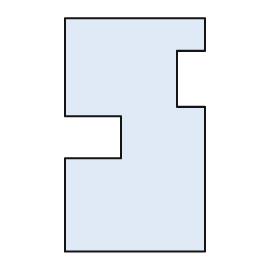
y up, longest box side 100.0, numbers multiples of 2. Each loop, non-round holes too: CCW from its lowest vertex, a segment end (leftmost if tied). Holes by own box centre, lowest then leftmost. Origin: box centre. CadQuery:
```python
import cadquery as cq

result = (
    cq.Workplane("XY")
    .moveTo(-30.0, -50.0)
    .lineTo(30.0, -50.0)
    .lineTo(30.0, 12.0)
    .lineTo(18.0, 12.0)
    .lineTo(18.0, 36.0)
    .lineTo(30.0, 36.0)
    .lineTo(30.0, 50.0)
    .lineTo(-30.0, 50.0)
    .lineTo(-30.0, 8.0)
    .lineTo(-6.0, 8.0)
    .lineTo(-6.0, -10.0)
    .lineTo(-30.0, -10.0)
    .close()
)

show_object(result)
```